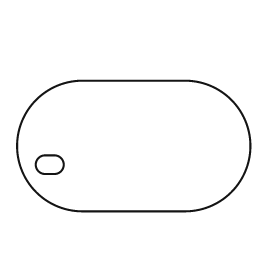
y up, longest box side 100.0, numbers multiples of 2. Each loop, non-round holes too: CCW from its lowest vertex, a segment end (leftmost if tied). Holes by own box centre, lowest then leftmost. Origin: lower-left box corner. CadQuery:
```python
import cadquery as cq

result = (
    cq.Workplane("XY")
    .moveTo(28.0, 0.0)
    .lineTo(72.0, 0.0)
    .threePointArc((100.0, 28.0), (72.0, 56.0))
    .lineTo(28.0, 56.0)
    .threePointArc((0.0, 28.0), (28.0, 0.0))
    .close()
    .moveTo(12.0, 16.0)
    .lineTo(16.0, 16.0)
    .threePointArc((20.0, 20.0), (16.0, 24.0))
    .lineTo(12.0, 24.0)
    .threePointArc((8.0, 20.0), (12.0, 16.0))
    .close()
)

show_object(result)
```